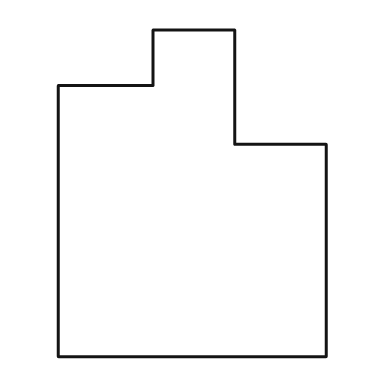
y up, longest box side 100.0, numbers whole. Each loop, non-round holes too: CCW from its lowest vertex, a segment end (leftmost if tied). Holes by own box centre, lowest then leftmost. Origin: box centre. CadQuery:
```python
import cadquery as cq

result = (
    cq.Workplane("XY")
    .moveTo(-41.0, -50.0)
    .lineTo(41.0, -50.0)
    .lineTo(41.0, 15.0)
    .lineTo(13.0, 15.0)
    .lineTo(13.0, 50.0)
    .lineTo(-12.0, 50.0)
    .lineTo(-12.0, 33.0)
    .lineTo(-41.0, 33.0)
    .close()
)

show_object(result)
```